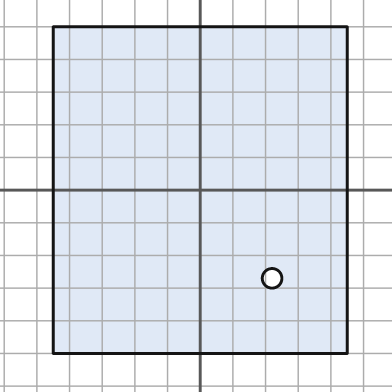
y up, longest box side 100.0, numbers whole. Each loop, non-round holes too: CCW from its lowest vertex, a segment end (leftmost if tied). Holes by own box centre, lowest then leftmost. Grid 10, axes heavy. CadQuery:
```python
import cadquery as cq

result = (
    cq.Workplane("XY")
    .moveTo(-45.0, -50.0)
    .lineTo(45.0, -50.0)
    .lineTo(45.0, 50.0)
    .lineTo(-45.0, 50.0)
    .close()
    .moveTo(22.0, -27.0)
    .circle(3.0)
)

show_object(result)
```